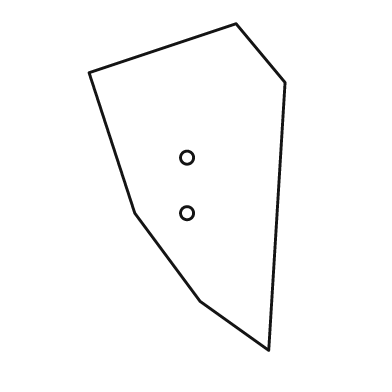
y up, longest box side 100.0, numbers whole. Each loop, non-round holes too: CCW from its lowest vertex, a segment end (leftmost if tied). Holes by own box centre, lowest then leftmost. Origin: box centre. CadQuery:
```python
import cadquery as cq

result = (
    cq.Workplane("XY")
    .moveTo(25.0, -50.0)
    .lineTo(30.0, 32.0)
    .lineTo(15.0, 50.0)
    .lineTo(-30.0, 35.0)
    .lineTo(-16.0, -8.0)
    .lineTo(4.0, -35.0)
    .close()
    .moveTo(0.0, -8.0)
    .circle(2.0)
    .moveTo(0.0, 9.0)
    .circle(2.0)
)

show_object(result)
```